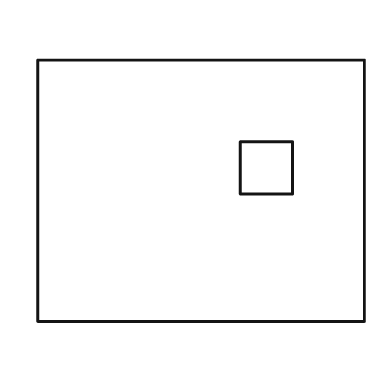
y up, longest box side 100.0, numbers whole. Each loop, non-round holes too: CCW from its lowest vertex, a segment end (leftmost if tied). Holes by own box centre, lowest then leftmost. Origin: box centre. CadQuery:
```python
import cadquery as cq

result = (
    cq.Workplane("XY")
    .moveTo(-50.0, -40.0)
    .lineTo(50.0, -40.0)
    .lineTo(50.0, 40.0)
    .lineTo(-50.0, 40.0)
    .close()
    .moveTo(12.0, -1.0)
    .lineTo(28.0, -1.0)
    .lineTo(28.0, 15.0)
    .lineTo(12.0, 15.0)
    .close()
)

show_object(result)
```